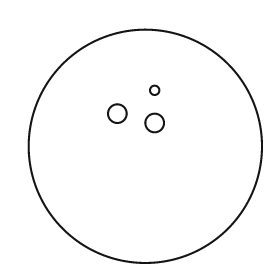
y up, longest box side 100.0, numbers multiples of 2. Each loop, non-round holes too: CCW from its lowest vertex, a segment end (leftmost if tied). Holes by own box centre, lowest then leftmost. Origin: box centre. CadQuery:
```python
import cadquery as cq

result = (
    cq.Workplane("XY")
    .moveTo(0.0, 0.0)
    .circle(50.0)
    .moveTo(4.0, 10.0)
    .circle(4.0)
    .moveTo(-12.0, 14.0)
    .circle(4.0)
    .moveTo(4.0, 24.0)
    .circle(2.0)
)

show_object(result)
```